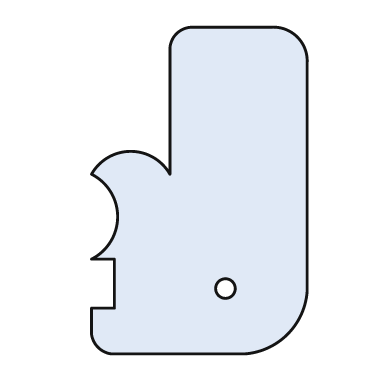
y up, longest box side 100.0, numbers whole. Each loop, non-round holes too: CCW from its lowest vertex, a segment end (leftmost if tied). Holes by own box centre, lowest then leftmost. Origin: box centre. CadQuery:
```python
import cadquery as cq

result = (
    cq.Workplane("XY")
    .moveTo(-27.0, -50.0)
    .lineTo(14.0, -50.0)
    .threePointArc((27.0, -44.0), (33.0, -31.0))
    .lineTo(33.0, 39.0)
    .threePointArc((30.0, 47.0), (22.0, 50.0))
    .lineTo(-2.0, 50.0)
    .threePointArc((-7.0, 48.0), (-9.0, 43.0))
    .lineTo(-9.0, 5.0)
    .threePointArc((-21.0, 12.0), (-33.0, 5.0))
    .threePointArc((-25.0, -8.0), (-33.0, -21.0))
    .lineTo(-26.0, -21.0)
    .lineTo(-26.0, -36.0)
    .lineTo(-33.0, -36.0)
    .lineTo(-33.0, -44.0)
    .threePointArc((-31.0, -48.0), (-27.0, -50.0))
    .close()
    .moveTo(8.0, -30.0)
    .circle(3.0)
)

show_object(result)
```